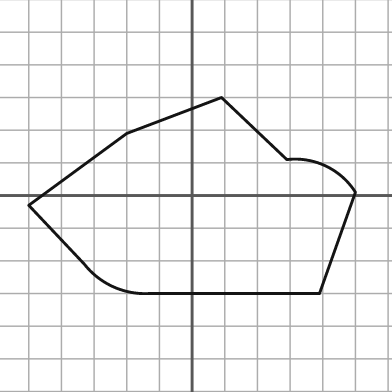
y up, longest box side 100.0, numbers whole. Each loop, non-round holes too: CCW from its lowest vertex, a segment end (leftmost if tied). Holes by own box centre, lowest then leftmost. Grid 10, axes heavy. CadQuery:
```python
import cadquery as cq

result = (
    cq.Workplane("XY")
    .moveTo(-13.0, -30.0)
    .lineTo(39.0, -30.0)
    .lineTo(50.0, 1.0)
    .threePointArc((41.0, 9.0), (29.0, 11.0))
    .lineTo(9.0, 30.0)
    .lineTo(-20.0, 19.0)
    .lineTo(-50.0, -3.0)
    .lineTo(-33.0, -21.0)
    .threePointArc((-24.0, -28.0), (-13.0, -30.0))
    .close()
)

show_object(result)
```